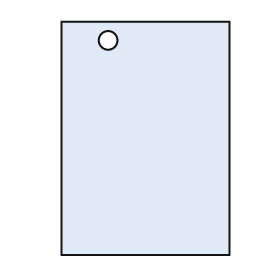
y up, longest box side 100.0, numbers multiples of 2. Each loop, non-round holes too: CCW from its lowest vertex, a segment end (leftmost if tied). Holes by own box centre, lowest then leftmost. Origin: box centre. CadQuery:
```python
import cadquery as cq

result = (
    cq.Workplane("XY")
    .moveTo(-36.0, -50.0)
    .lineTo(36.0, -50.0)
    .lineTo(36.0, 50.0)
    .lineTo(-36.0, 50.0)
    .close()
    .moveTo(-16.0, 42.0)
    .circle(4.0)
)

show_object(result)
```